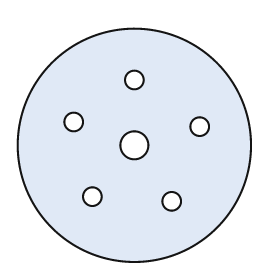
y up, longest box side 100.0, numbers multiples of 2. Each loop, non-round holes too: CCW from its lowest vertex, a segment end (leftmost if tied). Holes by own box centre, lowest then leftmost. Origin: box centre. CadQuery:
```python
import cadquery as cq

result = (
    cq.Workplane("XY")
    .moveTo(0.0, 0.0)
    .circle(50.0)
    .moveTo(16.0, -24.0)
    .circle(4.0)
    .moveTo(-18.0, -22.0)
    .circle(4.0)
    .moveTo(0.0, 0.0)
    .circle(6.0)
    .moveTo(28.0, 8.0)
    .circle(4.0)
    .moveTo(-26.0, 10.0)
    .circle(4.0)
    .moveTo(0.0, 28.0)
    .circle(4.0)
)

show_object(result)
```